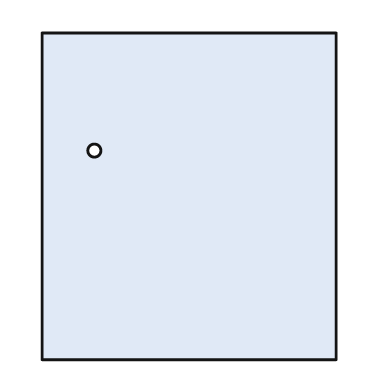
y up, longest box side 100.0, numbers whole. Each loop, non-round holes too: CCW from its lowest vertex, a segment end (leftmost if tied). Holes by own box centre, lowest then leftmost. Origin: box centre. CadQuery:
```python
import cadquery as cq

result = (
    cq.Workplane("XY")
    .moveTo(-45.0, -50.0)
    .lineTo(45.0, -50.0)
    .lineTo(45.0, 50.0)
    .lineTo(-45.0, 50.0)
    .close()
    .moveTo(-29.0, 14.0)
    .circle(2.0)
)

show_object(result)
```